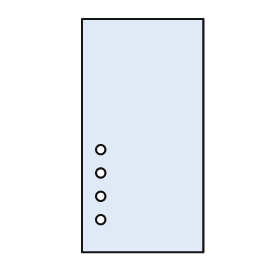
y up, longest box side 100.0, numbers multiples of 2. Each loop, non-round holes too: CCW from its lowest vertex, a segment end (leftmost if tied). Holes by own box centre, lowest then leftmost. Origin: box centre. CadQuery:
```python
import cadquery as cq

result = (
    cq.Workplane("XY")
    .moveTo(-26.0, -50.0)
    .lineTo(26.0, -50.0)
    .lineTo(26.0, 50.0)
    .lineTo(-26.0, 50.0)
    .close()
    .moveTo(-18.0, -36.0)
    .circle(2.0)
    .moveTo(-18.0, -26.0)
    .circle(2.0)
    .moveTo(-18.0, -16.0)
    .circle(2.0)
    .moveTo(-18.0, -6.0)
    .circle(2.0)
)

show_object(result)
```